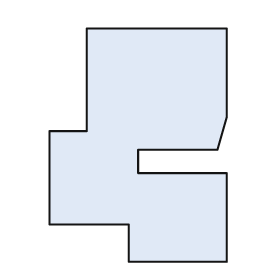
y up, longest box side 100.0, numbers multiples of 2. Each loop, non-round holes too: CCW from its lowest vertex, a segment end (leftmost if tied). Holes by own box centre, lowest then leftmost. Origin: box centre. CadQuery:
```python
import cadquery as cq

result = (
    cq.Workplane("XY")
    .moveTo(-4.0, -50.0)
    .lineTo(38.0, -50.0)
    .lineTo(38.0, -12.0)
    .lineTo(0.0, -12.0)
    .lineTo(0.0, -2.0)
    .lineTo(34.0, -2.0)
    .lineTo(38.0, 12.0)
    .lineTo(38.0, 50.0)
    .lineTo(-22.0, 50.0)
    .lineTo(-22.0, 6.0)
    .lineTo(-38.0, 6.0)
    .lineTo(-38.0, -34.0)
    .lineTo(-4.0, -34.0)
    .close()
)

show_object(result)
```